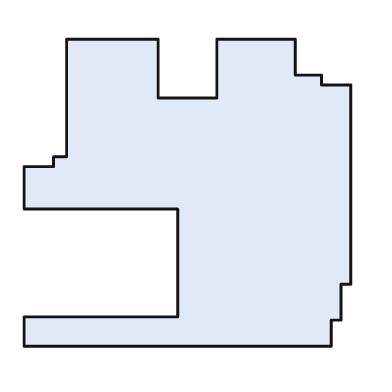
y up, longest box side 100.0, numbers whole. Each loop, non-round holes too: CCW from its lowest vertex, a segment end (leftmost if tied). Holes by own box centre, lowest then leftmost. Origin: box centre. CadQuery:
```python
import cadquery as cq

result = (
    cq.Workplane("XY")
    .moveTo(-50.0, -47.0)
    .lineTo(44.0, -47.0)
    .lineTo(44.0, -39.0)
    .lineTo(47.0, -39.0)
    .lineTo(47.0, -28.0)
    .lineTo(50.0, -28.0)
    .lineTo(50.0, 33.0)
    .lineTo(41.0, 33.0)
    .lineTo(41.0, 36.0)
    .lineTo(33.0, 36.0)
    .lineTo(33.0, 47.0)
    .lineTo(9.0, 47.0)
    .lineTo(9.0, 29.0)
    .lineTo(-9.0, 29.0)
    .lineTo(-9.0, 47.0)
    .lineTo(-37.0, 47.0)
    .lineTo(-37.0, 11.0)
    .lineTo(-41.0, 11.0)
    .lineTo(-41.0, 8.0)
    .lineTo(-50.0, 8.0)
    .lineTo(-50.0, -5.0)
    .lineTo(-3.0, -5.0)
    .lineTo(-3.0, -38.0)
    .lineTo(-50.0, -38.0)
    .close()
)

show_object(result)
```